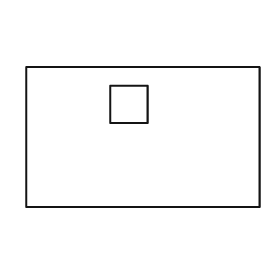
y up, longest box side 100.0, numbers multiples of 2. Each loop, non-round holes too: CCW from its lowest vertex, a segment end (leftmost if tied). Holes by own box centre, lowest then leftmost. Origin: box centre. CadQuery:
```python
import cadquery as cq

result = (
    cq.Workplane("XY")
    .moveTo(-50.0, -30.0)
    .lineTo(50.0, -30.0)
    .lineTo(50.0, 30.0)
    .lineTo(-50.0, 30.0)
    .close()
    .moveTo(-14.0, 6.0)
    .lineTo(2.0, 6.0)
    .lineTo(2.0, 22.0)
    .lineTo(-14.0, 22.0)
    .close()
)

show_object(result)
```